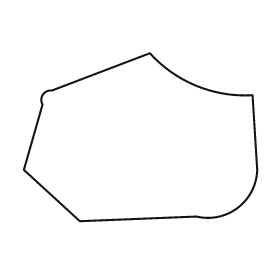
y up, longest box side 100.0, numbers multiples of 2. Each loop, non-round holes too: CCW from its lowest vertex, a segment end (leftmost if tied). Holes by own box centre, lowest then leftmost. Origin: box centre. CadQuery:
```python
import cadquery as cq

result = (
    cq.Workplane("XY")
    .moveTo(-26.0, -36.0)
    .lineTo(24.0, -34.0)
    .threePointArc((42.0, -30.0), (50.0, -14.0))
    .lineTo(48.0, 18.0)
    .threePointArc((24.0, 22.0), (4.0, 36.0))
    .lineTo(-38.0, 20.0)
    .threePointArc((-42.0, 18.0), (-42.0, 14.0))
    .lineTo(-50.0, -14.0)
    .close()
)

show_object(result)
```